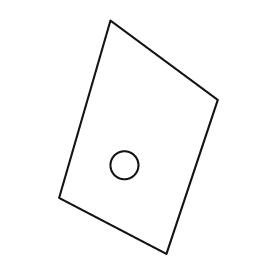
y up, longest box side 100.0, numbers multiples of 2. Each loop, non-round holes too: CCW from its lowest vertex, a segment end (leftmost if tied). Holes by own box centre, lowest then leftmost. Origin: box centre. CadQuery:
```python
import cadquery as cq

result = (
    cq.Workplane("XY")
    .moveTo(12.0, -50.0)
    .lineTo(34.0, 16.0)
    .lineTo(-12.0, 50.0)
    .lineTo(-34.0, -26.0)
    .close()
    .moveTo(-6.0, -12.0)
    .circle(6.0)
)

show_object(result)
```